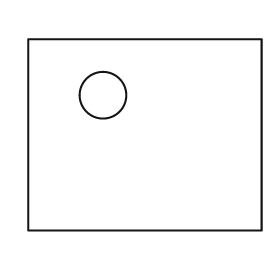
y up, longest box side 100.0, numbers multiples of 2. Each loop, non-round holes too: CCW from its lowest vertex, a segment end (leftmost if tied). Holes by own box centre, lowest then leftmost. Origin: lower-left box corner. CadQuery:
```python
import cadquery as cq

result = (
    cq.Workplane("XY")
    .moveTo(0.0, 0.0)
    .lineTo(100.0, 0.0)
    .lineTo(100.0, 82.0)
    .lineTo(0.0, 82.0)
    .close()
    .moveTo(32.0, 58.0)
    .circle(10.0)
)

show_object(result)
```